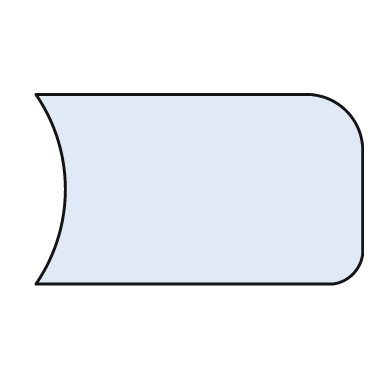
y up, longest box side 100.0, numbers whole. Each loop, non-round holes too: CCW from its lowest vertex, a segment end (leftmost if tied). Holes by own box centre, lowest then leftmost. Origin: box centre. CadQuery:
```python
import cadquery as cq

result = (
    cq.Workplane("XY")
    .moveTo(-50.0, -29.0)
    .lineTo(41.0, -29.0)
    .threePointArc((47.0, -26.0), (50.0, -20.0))
    .lineTo(50.0, 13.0)
    .threePointArc((45.0, 24.0), (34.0, 29.0))
    .lineTo(-50.0, 29.0)
    .threePointArc((-41.0, 0.0), (-50.0, -29.0))
    .close()
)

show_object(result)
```